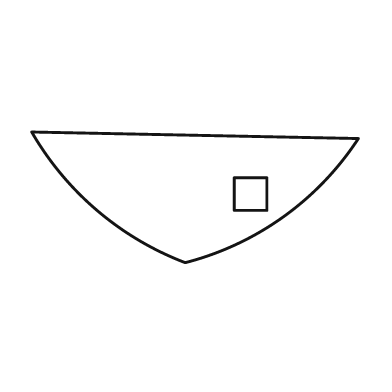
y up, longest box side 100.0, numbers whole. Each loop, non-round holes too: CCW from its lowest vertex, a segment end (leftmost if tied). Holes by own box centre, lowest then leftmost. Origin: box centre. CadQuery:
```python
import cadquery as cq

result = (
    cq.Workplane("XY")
    .moveTo(-3.0, -20.0)
    .threePointArc((27.0, -6.0), (50.0, 18.0))
    .lineTo(-50.0, 20.0)
    .threePointArc((-30.0, -4.0), (-3.0, -20.0))
    .close()
    .moveTo(12.0, -4.0)
    .lineTo(22.0, -4.0)
    .lineTo(22.0, 6.0)
    .lineTo(12.0, 6.0)
    .close()
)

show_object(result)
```